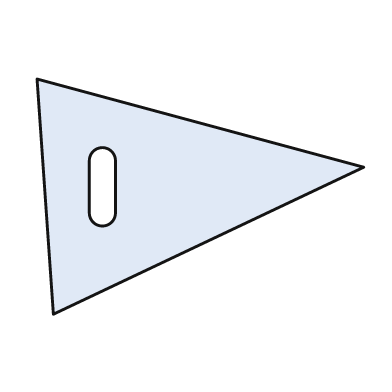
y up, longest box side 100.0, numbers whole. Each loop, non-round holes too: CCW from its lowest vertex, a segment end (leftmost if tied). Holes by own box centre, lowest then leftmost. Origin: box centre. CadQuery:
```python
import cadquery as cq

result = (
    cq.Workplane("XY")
    .moveTo(-45.0, -36.0)
    .lineTo(50.0, 9.0)
    .lineTo(-50.0, 36.0)
    .close()
    .moveTo(-34.0, -5.0)
    .threePointArc((-30.0, -9.0), (-26.0, -5.0))
    .lineTo(-26.0, 11.0)
    .threePointArc((-30.0, 15.0), (-34.0, 11.0))
    .close()
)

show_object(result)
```